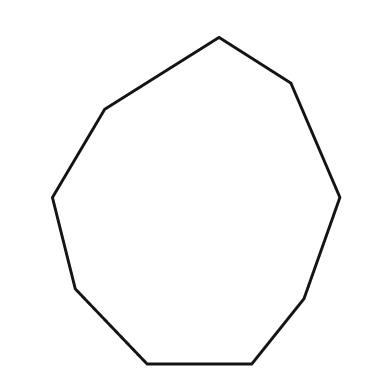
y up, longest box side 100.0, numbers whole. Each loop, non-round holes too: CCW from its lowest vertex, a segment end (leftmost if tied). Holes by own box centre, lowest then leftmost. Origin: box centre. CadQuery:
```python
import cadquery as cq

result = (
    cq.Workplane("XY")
    .moveTo(-15.0, -50.0)
    .lineTo(17.0, -50.0)
    .lineTo(33.0, -30.0)
    .lineTo(44.0, 1.0)
    .lineTo(29.0, 36.0)
    .lineTo(7.0, 50.0)
    .lineTo(-28.0, 28.0)
    .lineTo(-44.0, 1.0)
    .lineTo(-37.0, -27.0)
    .close()
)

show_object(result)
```